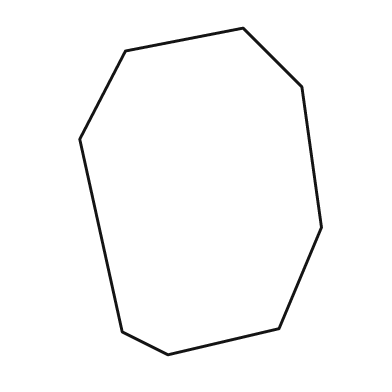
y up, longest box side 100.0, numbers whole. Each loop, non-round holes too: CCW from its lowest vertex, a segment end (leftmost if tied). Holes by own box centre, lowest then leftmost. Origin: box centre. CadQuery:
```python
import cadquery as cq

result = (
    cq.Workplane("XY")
    .moveTo(-10.0, -50.0)
    .lineTo(24.0, -42.0)
    .lineTo(37.0, -11.0)
    .lineTo(31.0, 32.0)
    .lineTo(13.0, 50.0)
    .lineTo(-23.0, 43.0)
    .lineTo(-37.0, 16.0)
    .lineTo(-24.0, -43.0)
    .close()
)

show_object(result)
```